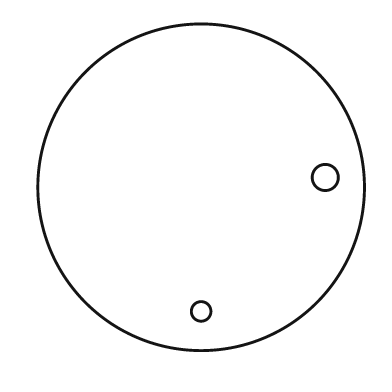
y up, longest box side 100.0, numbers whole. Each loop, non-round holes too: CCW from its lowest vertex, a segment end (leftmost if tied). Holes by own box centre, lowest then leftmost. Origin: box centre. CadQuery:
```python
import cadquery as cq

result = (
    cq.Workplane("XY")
    .moveTo(0.0, 0.0)
    .circle(50.0)
    .moveTo(0.0, -38.0)
    .circle(3.0)
    .moveTo(38.0, 3.0)
    .circle(4.0)
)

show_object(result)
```